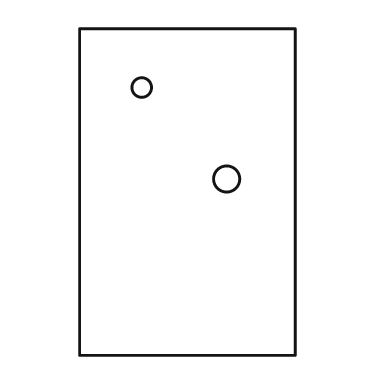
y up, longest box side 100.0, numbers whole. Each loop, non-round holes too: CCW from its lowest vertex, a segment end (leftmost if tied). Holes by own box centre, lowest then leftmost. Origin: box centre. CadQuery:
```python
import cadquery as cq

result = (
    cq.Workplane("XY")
    .moveTo(-33.0, -50.0)
    .lineTo(33.0, -50.0)
    .lineTo(33.0, 50.0)
    .lineTo(-33.0, 50.0)
    .close()
    .moveTo(12.0, 4.0)
    .circle(4.0)
    .moveTo(-14.0, 32.0)
    .circle(3.0)
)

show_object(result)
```